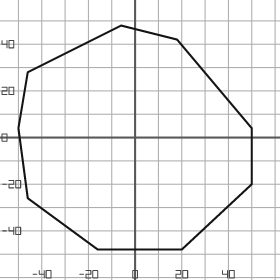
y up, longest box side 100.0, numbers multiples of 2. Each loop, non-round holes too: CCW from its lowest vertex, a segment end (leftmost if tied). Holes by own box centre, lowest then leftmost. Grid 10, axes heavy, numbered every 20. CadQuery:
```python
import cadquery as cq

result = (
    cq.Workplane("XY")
    .moveTo(-16.0, -48.0)
    .lineTo(20.0, -48.0)
    .lineTo(50.0, -20.0)
    .lineTo(50.0, 4.0)
    .lineTo(18.0, 42.0)
    .lineTo(-6.0, 48.0)
    .lineTo(-46.0, 28.0)
    .lineTo(-50.0, 4.0)
    .lineTo(-46.0, -26.0)
    .close()
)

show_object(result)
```